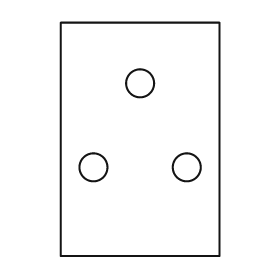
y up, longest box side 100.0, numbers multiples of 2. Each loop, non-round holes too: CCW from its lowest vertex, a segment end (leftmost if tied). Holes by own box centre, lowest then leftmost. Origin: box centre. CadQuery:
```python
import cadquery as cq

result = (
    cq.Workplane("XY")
    .moveTo(-34.0, -50.0)
    .lineTo(34.0, -50.0)
    .lineTo(34.0, 50.0)
    .lineTo(-34.0, 50.0)
    .close()
    .moveTo(-20.0, -12.0)
    .circle(6.0)
    .moveTo(20.0, -12.0)
    .circle(6.0)
    .moveTo(0.0, 24.0)
    .circle(6.0)
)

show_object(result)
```